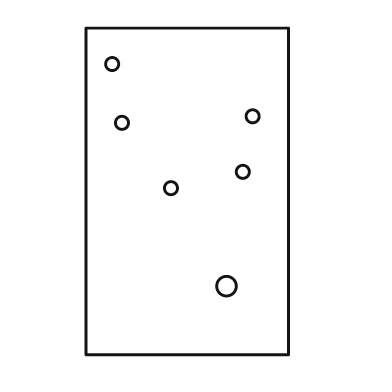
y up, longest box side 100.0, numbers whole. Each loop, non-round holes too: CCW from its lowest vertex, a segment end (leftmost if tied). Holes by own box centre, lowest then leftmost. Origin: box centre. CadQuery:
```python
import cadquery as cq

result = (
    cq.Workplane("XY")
    .moveTo(-31.0, -50.0)
    .lineTo(31.0, -50.0)
    .lineTo(31.0, 50.0)
    .lineTo(-31.0, 50.0)
    .close()
    .moveTo(12.0, -29.0)
    .circle(3.0)
    .moveTo(-5.0, 1.0)
    .circle(2.0)
    .moveTo(17.0, 6.0)
    .circle(2.0)
    .moveTo(-20.0, 21.0)
    .circle(2.0)
    .moveTo(20.0, 23.0)
    .circle(2.0)
    .moveTo(-23.0, 39.0)
    .circle(2.0)
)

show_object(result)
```